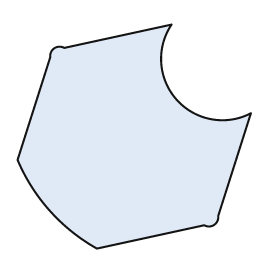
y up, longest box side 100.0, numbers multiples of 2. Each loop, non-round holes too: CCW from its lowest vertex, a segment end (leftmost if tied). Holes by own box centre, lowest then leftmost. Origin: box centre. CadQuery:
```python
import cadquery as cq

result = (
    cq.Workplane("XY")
    .moveTo(-16.0, -48.0)
    .lineTo(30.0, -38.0)
    .threePointArc((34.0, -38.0), (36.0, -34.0))
    .lineTo(50.0, 10.0)
    .threePointArc((18.0, 16.0), (16.0, 48.0))
    .lineTo(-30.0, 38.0)
    .threePointArc((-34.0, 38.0), (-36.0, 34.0))
    .lineTo(-50.0, -10.0)
    .threePointArc((-36.0, -32.0), (-16.0, -48.0))
    .close()
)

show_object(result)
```